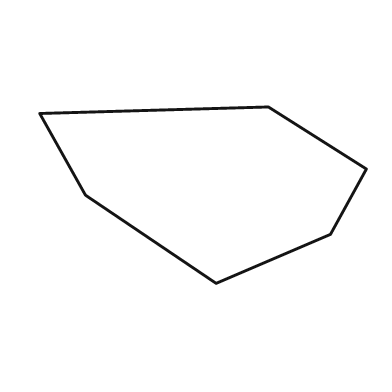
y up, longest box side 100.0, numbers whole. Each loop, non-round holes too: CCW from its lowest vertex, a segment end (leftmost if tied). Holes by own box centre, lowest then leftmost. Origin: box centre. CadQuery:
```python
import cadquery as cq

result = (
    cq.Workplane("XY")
    .moveTo(4.0, -27.0)
    .lineTo(39.0, -12.0)
    .lineTo(50.0, 8.0)
    .lineTo(20.0, 27.0)
    .lineTo(-50.0, 25.0)
    .lineTo(-36.0, 0.0)
    .close()
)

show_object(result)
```